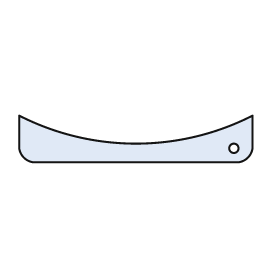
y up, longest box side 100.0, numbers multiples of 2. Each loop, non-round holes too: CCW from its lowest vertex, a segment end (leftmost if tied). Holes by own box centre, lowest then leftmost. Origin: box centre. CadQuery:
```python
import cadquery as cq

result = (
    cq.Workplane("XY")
    .moveTo(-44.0, -10.0)
    .lineTo(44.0, -10.0)
    .threePointArc((48.0, -8.0), (50.0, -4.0))
    .lineTo(50.0, 10.0)
    .threePointArc((0.0, -2.0), (-50.0, 10.0))
    .lineTo(-50.0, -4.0)
    .threePointArc((-48.0, -8.0), (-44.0, -10.0))
    .close()
    .moveTo(42.0, -4.0)
    .circle(2.0)
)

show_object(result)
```